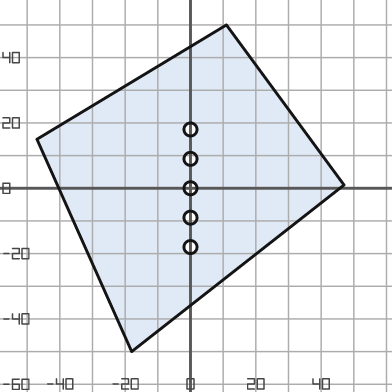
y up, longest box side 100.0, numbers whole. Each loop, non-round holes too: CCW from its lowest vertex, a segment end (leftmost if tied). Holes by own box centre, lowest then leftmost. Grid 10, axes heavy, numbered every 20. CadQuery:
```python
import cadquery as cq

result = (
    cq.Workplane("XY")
    .moveTo(-18.0, -50.0)
    .lineTo(47.0, 1.0)
    .lineTo(11.0, 50.0)
    .lineTo(-47.0, 15.0)
    .close()
    .moveTo(0.0, -18.0)
    .circle(2.0)
    .moveTo(0.0, -9.0)
    .circle(2.0)
    .moveTo(0.0, 0.0)
    .circle(2.0)
    .moveTo(0.0, 9.0)
    .circle(2.0)
    .moveTo(0.0, 18.0)
    .circle(2.0)
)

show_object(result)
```